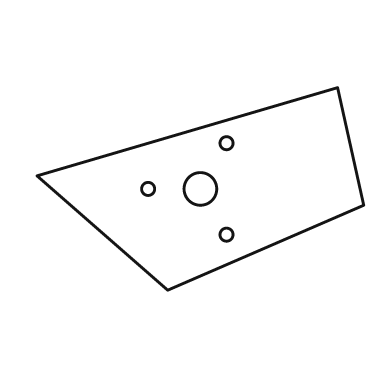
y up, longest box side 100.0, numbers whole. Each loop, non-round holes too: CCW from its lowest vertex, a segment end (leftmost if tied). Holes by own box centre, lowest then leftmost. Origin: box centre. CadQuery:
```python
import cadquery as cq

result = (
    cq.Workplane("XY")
    .moveTo(-10.0, -31.0)
    .lineTo(50.0, -5.0)
    .lineTo(42.0, 31.0)
    .lineTo(-50.0, 4.0)
    .close()
    .moveTo(8.0, -14.0)
    .circle(2.0)
    .moveTo(-16.0, 0.0)
    .circle(2.0)
    .moveTo(0.0, 0.0)
    .circle(5.0)
    .moveTo(8.0, 14.0)
    .circle(2.0)
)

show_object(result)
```